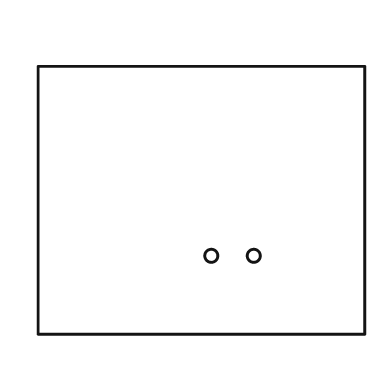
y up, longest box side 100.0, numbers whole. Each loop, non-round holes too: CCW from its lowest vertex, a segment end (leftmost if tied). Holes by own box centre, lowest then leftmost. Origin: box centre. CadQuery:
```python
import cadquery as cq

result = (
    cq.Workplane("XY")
    .moveTo(-50.0, -41.0)
    .lineTo(50.0, -41.0)
    .lineTo(50.0, 41.0)
    .lineTo(-50.0, 41.0)
    .close()
    .moveTo(3.0, -17.0)
    .circle(2.0)
    .moveTo(16.0, -17.0)
    .circle(2.0)
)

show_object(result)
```